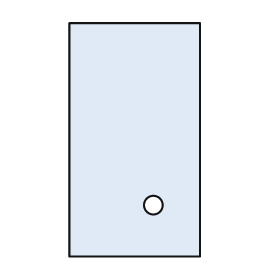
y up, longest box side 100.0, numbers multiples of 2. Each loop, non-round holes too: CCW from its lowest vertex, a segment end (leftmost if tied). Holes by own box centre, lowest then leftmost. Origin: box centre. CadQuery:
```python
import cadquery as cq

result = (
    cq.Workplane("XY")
    .moveTo(-28.0, -50.0)
    .lineTo(28.0, -50.0)
    .lineTo(28.0, 50.0)
    .lineTo(-28.0, 50.0)
    .close()
    .moveTo(8.0, -28.0)
    .circle(4.0)
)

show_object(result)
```